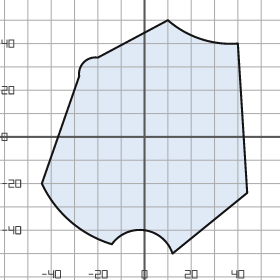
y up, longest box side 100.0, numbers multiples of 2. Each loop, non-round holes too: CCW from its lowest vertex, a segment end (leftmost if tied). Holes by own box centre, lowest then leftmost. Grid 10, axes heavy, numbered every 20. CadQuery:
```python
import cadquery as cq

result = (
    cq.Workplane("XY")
    .moveTo(12.0, -50.0)
    .lineTo(44.0, -24.0)
    .lineTo(40.0, 40.0)
    .threePointArc((24.0, 42.0), (10.0, 50.0))
    .lineTo(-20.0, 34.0)
    .threePointArc((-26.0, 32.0), (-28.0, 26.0))
    .lineTo(-44.0, -20.0)
    .threePointArc((-32.0, -36.0), (-14.0, -46.0))
    .threePointArc((0.0, -40.0), (12.0, -50.0))
    .close()
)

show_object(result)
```